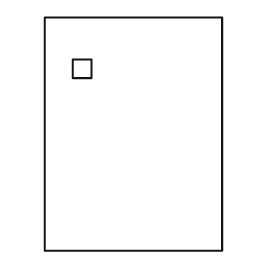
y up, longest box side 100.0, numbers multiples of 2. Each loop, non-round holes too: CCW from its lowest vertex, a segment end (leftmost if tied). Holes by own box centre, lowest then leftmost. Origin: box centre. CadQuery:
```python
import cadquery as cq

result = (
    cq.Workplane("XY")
    .moveTo(-38.0, -50.0)
    .lineTo(38.0, -50.0)
    .lineTo(38.0, 50.0)
    .lineTo(-38.0, 50.0)
    .close()
    .moveTo(-26.0, 24.0)
    .lineTo(-18.0, 24.0)
    .lineTo(-18.0, 32.0)
    .lineTo(-26.0, 32.0)
    .close()
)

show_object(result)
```